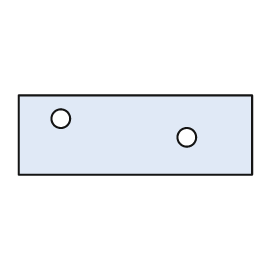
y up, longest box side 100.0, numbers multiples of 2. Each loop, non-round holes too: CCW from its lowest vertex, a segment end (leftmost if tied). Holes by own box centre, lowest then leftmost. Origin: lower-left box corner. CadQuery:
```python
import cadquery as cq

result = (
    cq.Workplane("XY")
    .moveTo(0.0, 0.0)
    .lineTo(100.0, 0.0)
    .lineTo(100.0, 34.0)
    .lineTo(0.0, 34.0)
    .close()
    .moveTo(72.0, 16.0)
    .circle(4.0)
    .moveTo(18.0, 24.0)
    .circle(4.0)
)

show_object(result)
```